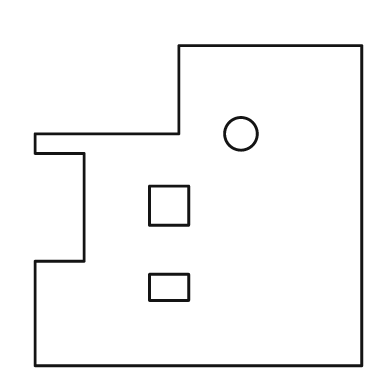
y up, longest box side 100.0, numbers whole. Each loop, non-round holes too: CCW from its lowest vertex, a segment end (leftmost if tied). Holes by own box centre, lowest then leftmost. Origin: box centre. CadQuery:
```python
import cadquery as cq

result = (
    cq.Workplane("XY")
    .moveTo(-50.0, -49.0)
    .lineTo(50.0, -49.0)
    .lineTo(50.0, 49.0)
    .lineTo(-6.0, 49.0)
    .lineTo(-6.0, 22.0)
    .lineTo(-50.0, 22.0)
    .lineTo(-50.0, 16.0)
    .lineTo(-35.0, 16.0)
    .lineTo(-35.0, -17.0)
    .lineTo(-50.0, -17.0)
    .close()
    .moveTo(-15.0, -29.0)
    .lineTo(-3.0, -29.0)
    .lineTo(-3.0, -21.0)
    .lineTo(-15.0, -21.0)
    .close()
    .moveTo(-15.0, -6.0)
    .lineTo(-3.0, -6.0)
    .lineTo(-3.0, 6.0)
    .lineTo(-15.0, 6.0)
    .close()
    .moveTo(13.0, 22.0)
    .circle(5.0)
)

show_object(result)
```